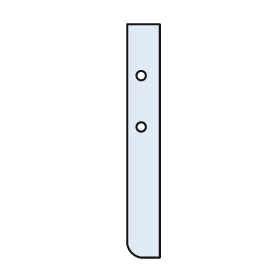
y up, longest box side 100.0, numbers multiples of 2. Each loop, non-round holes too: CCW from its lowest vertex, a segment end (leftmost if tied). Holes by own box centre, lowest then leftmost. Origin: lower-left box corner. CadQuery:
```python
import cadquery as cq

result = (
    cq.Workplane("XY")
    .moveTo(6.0, 0.0)
    .lineTo(14.0, 0.0)
    .lineTo(14.0, 100.0)
    .lineTo(0.0, 100.0)
    .lineTo(0.0, 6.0)
    .threePointArc((2.0, 2.0), (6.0, 0.0))
    .close()
    .moveTo(6.0, 56.0)
    .circle(2.0)
    .moveTo(6.0, 78.0)
    .circle(2.0)
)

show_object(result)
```